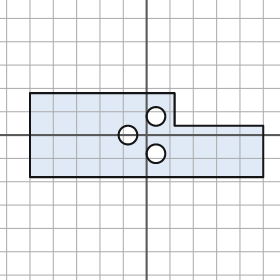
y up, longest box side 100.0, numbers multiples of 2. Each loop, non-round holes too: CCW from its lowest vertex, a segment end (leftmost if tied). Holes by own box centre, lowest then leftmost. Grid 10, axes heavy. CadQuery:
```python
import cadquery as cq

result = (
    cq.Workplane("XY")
    .moveTo(-50.0, -18.0)
    .lineTo(50.0, -18.0)
    .lineTo(50.0, 4.0)
    .lineTo(12.0, 4.0)
    .lineTo(12.0, 18.0)
    .lineTo(-50.0, 18.0)
    .close()
    .moveTo(4.0, -8.0)
    .circle(4.0)
    .moveTo(-8.0, 0.0)
    .circle(4.0)
    .moveTo(4.0, 8.0)
    .circle(4.0)
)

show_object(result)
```